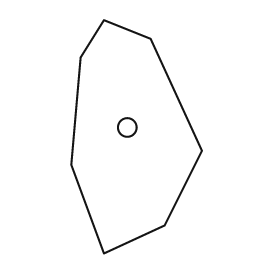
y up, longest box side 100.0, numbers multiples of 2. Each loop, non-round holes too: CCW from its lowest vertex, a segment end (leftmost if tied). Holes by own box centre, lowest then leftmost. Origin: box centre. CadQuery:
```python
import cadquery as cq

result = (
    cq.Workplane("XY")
    .moveTo(-14.0, -50.0)
    .lineTo(12.0, -38.0)
    .lineTo(28.0, -6.0)
    .lineTo(6.0, 42.0)
    .lineTo(-14.0, 50.0)
    .lineTo(-24.0, 34.0)
    .lineTo(-28.0, -12.0)
    .close()
    .moveTo(-4.0, 4.0)
    .circle(4.0)
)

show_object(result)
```